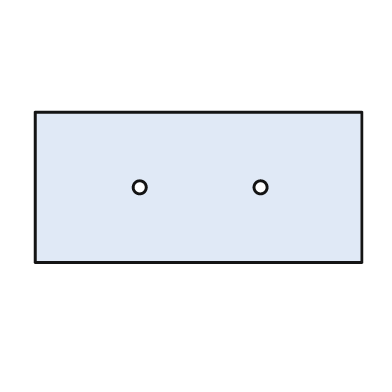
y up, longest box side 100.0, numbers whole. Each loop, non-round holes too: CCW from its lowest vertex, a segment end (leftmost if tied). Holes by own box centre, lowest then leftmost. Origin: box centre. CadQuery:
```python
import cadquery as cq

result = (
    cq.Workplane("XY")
    .moveTo(-50.0, -23.0)
    .lineTo(50.0, -23.0)
    .lineTo(50.0, 23.0)
    .lineTo(-50.0, 23.0)
    .close()
    .moveTo(-18.0, 0.0)
    .circle(2.0)
    .moveTo(19.0, 0.0)
    .circle(2.0)
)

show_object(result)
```